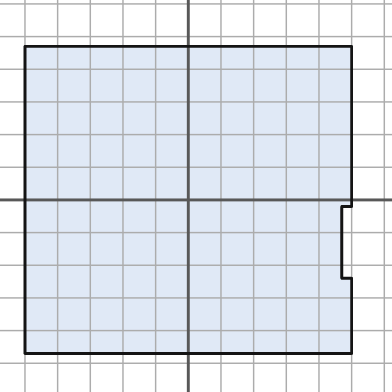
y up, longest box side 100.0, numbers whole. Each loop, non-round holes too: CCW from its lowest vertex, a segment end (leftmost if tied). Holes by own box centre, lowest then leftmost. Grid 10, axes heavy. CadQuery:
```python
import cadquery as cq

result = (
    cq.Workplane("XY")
    .moveTo(-50.0, -47.0)
    .lineTo(50.0, -47.0)
    .lineTo(50.0, -24.0)
    .lineTo(47.0, -24.0)
    .lineTo(47.0, -2.0)
    .lineTo(50.0, -2.0)
    .lineTo(50.0, 47.0)
    .lineTo(-50.0, 47.0)
    .close()
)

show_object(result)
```